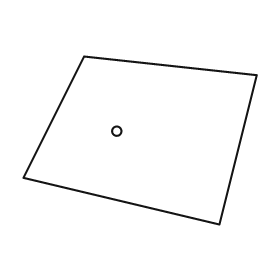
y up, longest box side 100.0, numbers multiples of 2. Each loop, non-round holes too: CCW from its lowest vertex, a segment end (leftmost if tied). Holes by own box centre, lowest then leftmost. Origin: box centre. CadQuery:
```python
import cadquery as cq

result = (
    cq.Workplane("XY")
    .moveTo(34.0, -36.0)
    .lineTo(50.0, 28.0)
    .lineTo(-24.0, 36.0)
    .lineTo(-50.0, -16.0)
    .close()
    .moveTo(-10.0, 4.0)
    .circle(2.0)
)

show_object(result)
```